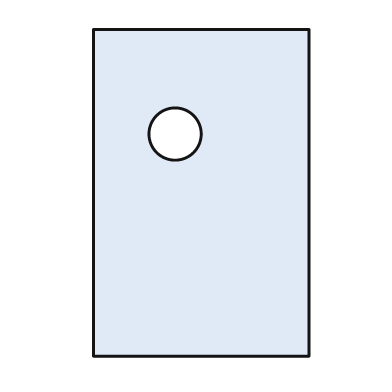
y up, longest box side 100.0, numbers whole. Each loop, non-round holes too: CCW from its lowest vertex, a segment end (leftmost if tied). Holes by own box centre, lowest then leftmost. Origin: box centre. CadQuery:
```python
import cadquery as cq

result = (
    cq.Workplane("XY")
    .moveTo(-33.0, -50.0)
    .lineTo(33.0, -50.0)
    .lineTo(33.0, 50.0)
    .lineTo(-33.0, 50.0)
    .close()
    .moveTo(-8.0, 18.0)
    .circle(8.0)
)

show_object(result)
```